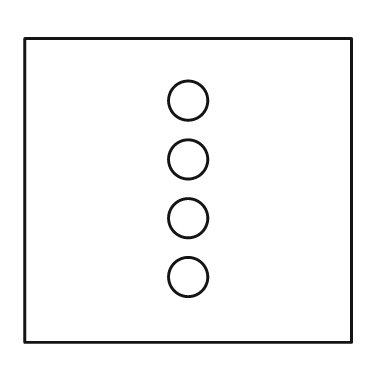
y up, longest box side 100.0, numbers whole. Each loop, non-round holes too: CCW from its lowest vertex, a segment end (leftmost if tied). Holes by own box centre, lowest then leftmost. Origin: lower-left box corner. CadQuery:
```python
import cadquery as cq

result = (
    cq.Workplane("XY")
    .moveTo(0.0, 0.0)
    .lineTo(100.0, 0.0)
    .lineTo(100.0, 93.0)
    .lineTo(0.0, 93.0)
    .close()
    .moveTo(50.0, 20.0)
    .circle(6.0)
    .moveTo(50.0, 38.0)
    .circle(6.0)
    .moveTo(50.0, 56.0)
    .circle(6.0)
    .moveTo(50.0, 74.0)
    .circle(6.0)
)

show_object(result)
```